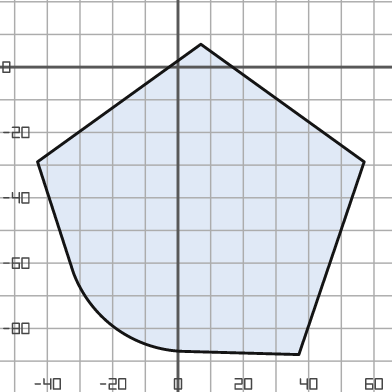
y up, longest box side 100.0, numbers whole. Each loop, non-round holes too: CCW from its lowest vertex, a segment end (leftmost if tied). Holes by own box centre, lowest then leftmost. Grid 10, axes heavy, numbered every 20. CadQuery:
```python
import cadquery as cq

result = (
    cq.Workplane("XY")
    .moveTo(37.0, -88.0)
    .lineTo(57.0, -29.0)
    .lineTo(7.0, 7.0)
    .lineTo(-43.0, -29.0)
    .lineTo(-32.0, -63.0)
    .threePointArc((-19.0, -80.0), (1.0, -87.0))
    .close()
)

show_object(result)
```